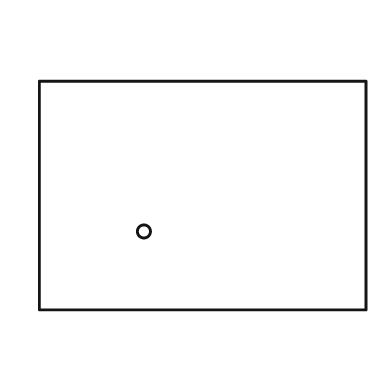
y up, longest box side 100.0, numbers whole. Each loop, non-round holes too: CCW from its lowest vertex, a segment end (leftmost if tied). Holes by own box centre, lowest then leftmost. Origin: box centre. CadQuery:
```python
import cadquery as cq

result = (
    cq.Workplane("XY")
    .moveTo(-50.0, -35.0)
    .lineTo(50.0, -35.0)
    .lineTo(50.0, 35.0)
    .lineTo(-50.0, 35.0)
    .close()
    .moveTo(-18.0, -11.0)
    .circle(2.0)
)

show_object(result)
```